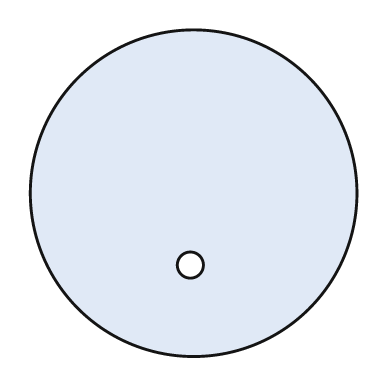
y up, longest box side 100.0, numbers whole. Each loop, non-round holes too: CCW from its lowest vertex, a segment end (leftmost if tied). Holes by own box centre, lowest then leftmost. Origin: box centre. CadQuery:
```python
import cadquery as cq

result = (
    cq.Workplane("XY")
    .moveTo(0.0, 0.0)
    .circle(50.0)
    .moveTo(-1.0, -22.0)
    .circle(4.0)
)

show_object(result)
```